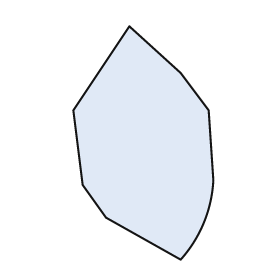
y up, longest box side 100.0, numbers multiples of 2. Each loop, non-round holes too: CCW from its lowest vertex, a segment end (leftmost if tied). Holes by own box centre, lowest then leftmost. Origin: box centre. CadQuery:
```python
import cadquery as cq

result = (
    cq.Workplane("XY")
    .moveTo(16.0, -50.0)
    .threePointArc((26.0, -34.0), (30.0, -16.0))
    .lineTo(28.0, 14.0)
    .lineTo(16.0, 30.0)
    .lineTo(-6.0, 50.0)
    .lineTo(-30.0, 14.0)
    .lineTo(-26.0, -18.0)
    .lineTo(-16.0, -32.0)
    .close()
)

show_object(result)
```